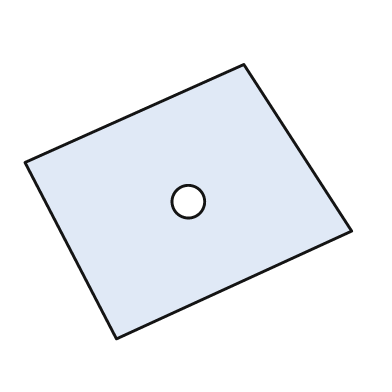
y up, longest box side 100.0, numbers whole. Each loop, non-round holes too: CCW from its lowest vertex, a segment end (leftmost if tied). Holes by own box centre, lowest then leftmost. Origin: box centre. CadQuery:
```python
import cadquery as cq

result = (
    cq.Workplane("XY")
    .moveTo(-22.0, -42.0)
    .lineTo(50.0, -9.0)
    .lineTo(17.0, 42.0)
    .lineTo(-50.0, 12.0)
    .close()
    .moveTo(0.0, 0.0)
    .circle(5.0)
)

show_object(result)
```